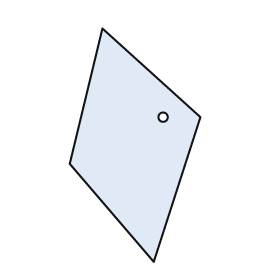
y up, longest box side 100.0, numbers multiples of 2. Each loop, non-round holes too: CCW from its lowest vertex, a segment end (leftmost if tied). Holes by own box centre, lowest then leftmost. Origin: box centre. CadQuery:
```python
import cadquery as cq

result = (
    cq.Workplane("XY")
    .moveTo(8.0, -50.0)
    .lineTo(28.0, 12.0)
    .lineTo(-14.0, 50.0)
    .lineTo(-28.0, -8.0)
    .close()
    .moveTo(12.0, 12.0)
    .circle(2.0)
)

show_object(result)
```